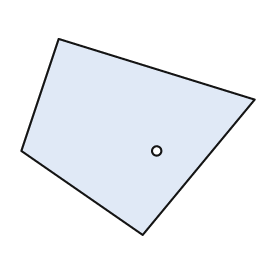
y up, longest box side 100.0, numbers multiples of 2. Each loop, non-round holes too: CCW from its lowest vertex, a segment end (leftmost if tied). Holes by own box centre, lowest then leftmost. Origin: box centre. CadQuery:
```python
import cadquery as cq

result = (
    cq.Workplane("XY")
    .moveTo(2.0, -42.0)
    .lineTo(50.0, 16.0)
    .lineTo(-34.0, 42.0)
    .lineTo(-50.0, -6.0)
    .close()
    .moveTo(8.0, -6.0)
    .circle(2.0)
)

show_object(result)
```